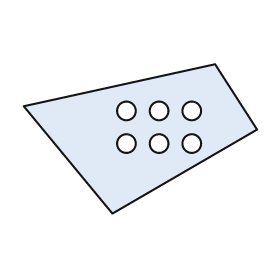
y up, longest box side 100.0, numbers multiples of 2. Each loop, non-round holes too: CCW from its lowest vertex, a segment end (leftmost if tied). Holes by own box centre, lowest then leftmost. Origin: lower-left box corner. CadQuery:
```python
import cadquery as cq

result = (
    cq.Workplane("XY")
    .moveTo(38.0, 0.0)
    .lineTo(100.0, 36.0)
    .lineTo(82.0, 64.0)
    .lineTo(0.0, 46.0)
    .close()
    .moveTo(44.0, 30.0)
    .circle(4.0)
    .moveTo(58.0, 30.0)
    .circle(4.0)
    .moveTo(72.0, 30.0)
    .circle(4.0)
    .moveTo(44.0, 44.0)
    .circle(4.0)
    .moveTo(58.0, 44.0)
    .circle(4.0)
    .moveTo(72.0, 44.0)
    .circle(4.0)
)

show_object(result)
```